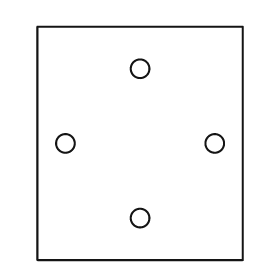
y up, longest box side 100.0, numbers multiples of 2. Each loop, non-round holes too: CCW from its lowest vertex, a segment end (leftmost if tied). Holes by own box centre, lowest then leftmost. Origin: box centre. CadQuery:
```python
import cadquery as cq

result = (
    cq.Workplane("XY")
    .moveTo(-44.0, -50.0)
    .lineTo(44.0, -50.0)
    .lineTo(44.0, 50.0)
    .lineTo(-44.0, 50.0)
    .close()
    .moveTo(0.0, -32.0)
    .circle(4.0)
    .moveTo(-32.0, 0.0)
    .circle(4.0)
    .moveTo(32.0, 0.0)
    .circle(4.0)
    .moveTo(0.0, 32.0)
    .circle(4.0)
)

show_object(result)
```